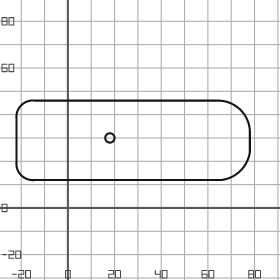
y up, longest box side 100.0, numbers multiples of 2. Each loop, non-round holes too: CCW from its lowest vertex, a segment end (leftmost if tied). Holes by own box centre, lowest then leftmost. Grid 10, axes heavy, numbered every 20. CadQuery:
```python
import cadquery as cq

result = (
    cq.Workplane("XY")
    .moveTo(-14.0, 12.0)
    .lineTo(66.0, 12.0)
    .threePointArc((74.0, 16.0), (78.0, 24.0))
    .lineTo(78.0, 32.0)
    .threePointArc((74.0, 42.0), (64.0, 46.0))
    .lineTo(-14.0, 46.0)
    .threePointArc((-20.0, 44.0), (-22.0, 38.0))
    .lineTo(-22.0, 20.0)
    .threePointArc((-20.0, 14.0), (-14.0, 12.0))
    .close()
    .moveTo(18.0, 30.0)
    .circle(2.0)
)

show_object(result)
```